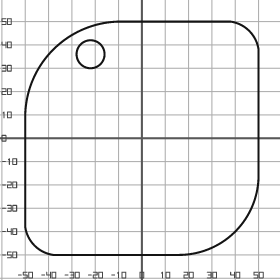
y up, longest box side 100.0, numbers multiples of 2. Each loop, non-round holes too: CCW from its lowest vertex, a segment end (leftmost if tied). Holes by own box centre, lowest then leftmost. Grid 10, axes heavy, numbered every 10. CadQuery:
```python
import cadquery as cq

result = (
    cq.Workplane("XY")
    .moveTo(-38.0, -50.0)
    .lineTo(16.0, -50.0)
    .threePointArc((40.0, -40.0), (50.0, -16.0))
    .lineTo(50.0, 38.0)
    .threePointArc((46.0, 46.0), (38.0, 50.0))
    .lineTo(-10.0, 50.0)
    .threePointArc((-38.0, 38.0), (-50.0, 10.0))
    .lineTo(-50.0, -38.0)
    .threePointArc((-46.0, -46.0), (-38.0, -50.0))
    .close()
    .moveTo(-22.0, 36.0)
    .circle(6.0)
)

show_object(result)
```